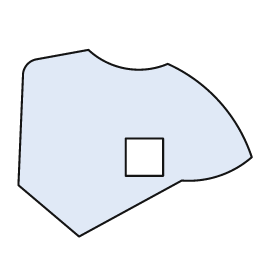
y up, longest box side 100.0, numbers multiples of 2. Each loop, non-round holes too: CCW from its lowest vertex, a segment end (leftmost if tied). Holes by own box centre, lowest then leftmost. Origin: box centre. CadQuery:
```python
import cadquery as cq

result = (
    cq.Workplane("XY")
    .moveTo(-24.0, -40.0)
    .lineTo(20.0, -16.0)
    .threePointArc((36.0, -14.0), (50.0, -6.0))
    .threePointArc((36.0, 18.0), (14.0, 34.0))
    .threePointArc((-4.0, 32.0), (-20.0, 40.0))
    .lineTo(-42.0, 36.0)
    .threePointArc((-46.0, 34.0), (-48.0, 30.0))
    .lineTo(-50.0, -18.0)
    .close()
    .moveTo(-4.0, -14.0)
    .lineTo(12.0, -14.0)
    .lineTo(12.0, 2.0)
    .lineTo(-4.0, 2.0)
    .close()
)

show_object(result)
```